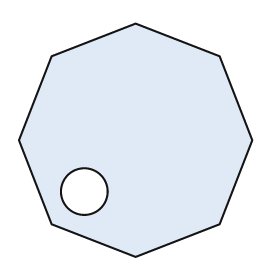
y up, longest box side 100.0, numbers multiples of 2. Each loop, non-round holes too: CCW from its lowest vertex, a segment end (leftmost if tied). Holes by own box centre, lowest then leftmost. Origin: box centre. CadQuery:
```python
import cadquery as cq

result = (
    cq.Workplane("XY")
    .moveTo(0.0, -50.0)
    .lineTo(36.0, -36.0)
    .lineTo(50.0, 0.0)
    .lineTo(36.0, 36.0)
    .lineTo(0.0, 50.0)
    .lineTo(-36.0, 36.0)
    .lineTo(-50.0, 0.0)
    .lineTo(-36.0, -36.0)
    .close()
    .moveTo(-22.0, -22.0)
    .circle(10.0)
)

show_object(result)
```